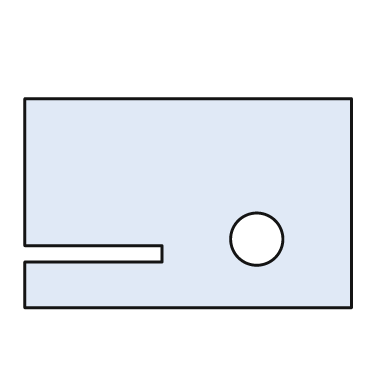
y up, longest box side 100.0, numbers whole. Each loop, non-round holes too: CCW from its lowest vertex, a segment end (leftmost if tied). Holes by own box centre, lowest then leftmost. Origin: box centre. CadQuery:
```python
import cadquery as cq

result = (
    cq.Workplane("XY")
    .moveTo(-50.0, -32.0)
    .lineTo(50.0, -32.0)
    .lineTo(50.0, 32.0)
    .lineTo(-50.0, 32.0)
    .lineTo(-50.0, -13.0)
    .lineTo(-8.0, -13.0)
    .lineTo(-8.0, -18.0)
    .lineTo(-50.0, -18.0)
    .close()
    .moveTo(21.0, -11.0)
    .circle(8.0)
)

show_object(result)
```